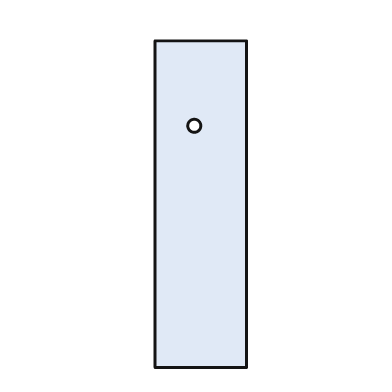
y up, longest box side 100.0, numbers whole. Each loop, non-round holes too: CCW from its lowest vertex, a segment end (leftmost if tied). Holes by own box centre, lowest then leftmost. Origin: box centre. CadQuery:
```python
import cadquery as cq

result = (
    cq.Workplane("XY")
    .moveTo(-14.0, -50.0)
    .lineTo(14.0, -50.0)
    .lineTo(14.0, 50.0)
    .lineTo(-14.0, 50.0)
    .close()
    .moveTo(-2.0, 24.0)
    .circle(2.0)
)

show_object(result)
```